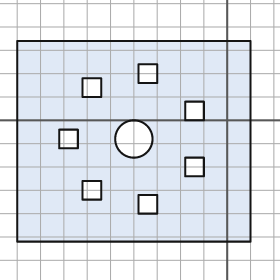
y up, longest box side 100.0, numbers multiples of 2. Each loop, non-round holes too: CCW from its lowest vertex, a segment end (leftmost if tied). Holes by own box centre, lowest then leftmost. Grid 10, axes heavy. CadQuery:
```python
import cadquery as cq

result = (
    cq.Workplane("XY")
    .moveTo(-90.0, -52.0)
    .lineTo(10.0, -52.0)
    .lineTo(10.0, 34.0)
    .lineTo(-90.0, 34.0)
    .close()
    .moveTo(-38.0, -40.0)
    .lineTo(-30.0, -40.0)
    .lineTo(-30.0, -32.0)
    .lineTo(-38.0, -32.0)
    .close()
    .moveTo(-62.0, -34.0)
    .lineTo(-54.0, -34.0)
    .lineTo(-54.0, -26.0)
    .lineTo(-62.0, -26.0)
    .close()
    .moveTo(-18.0, -24.0)
    .lineTo(-10.0, -24.0)
    .lineTo(-10.0, -16.0)
    .lineTo(-18.0, -16.0)
    .close()
    .moveTo(-72.0, -12.0)
    .lineTo(-64.0, -12.0)
    .lineTo(-64.0, -4.0)
    .lineTo(-72.0, -4.0)
    .close()
    .moveTo(-40.0, -8.0)
    .circle(8.0)
    .moveTo(-18.0, 0.0)
    .lineTo(-10.0, 0.0)
    .lineTo(-10.0, 8.0)
    .lineTo(-18.0, 8.0)
    .close()
    .moveTo(-62.0, 10.0)
    .lineTo(-54.0, 10.0)
    .lineTo(-54.0, 18.0)
    .lineTo(-62.0, 18.0)
    .close()
    .moveTo(-38.0, 16.0)
    .lineTo(-30.0, 16.0)
    .lineTo(-30.0, 24.0)
    .lineTo(-38.0, 24.0)
    .close()
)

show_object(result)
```